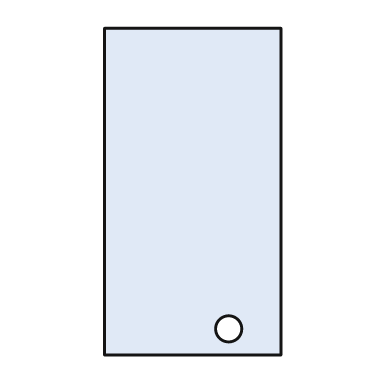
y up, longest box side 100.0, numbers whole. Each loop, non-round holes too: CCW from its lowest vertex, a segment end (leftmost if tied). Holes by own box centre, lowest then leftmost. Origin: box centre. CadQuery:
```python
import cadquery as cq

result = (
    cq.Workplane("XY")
    .moveTo(-27.0, -50.0)
    .lineTo(27.0, -50.0)
    .lineTo(27.0, 50.0)
    .lineTo(-27.0, 50.0)
    .close()
    .moveTo(11.0, -42.0)
    .circle(4.0)
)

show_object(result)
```